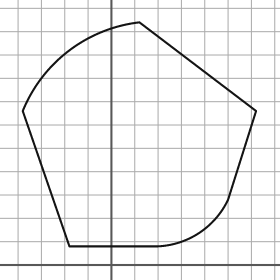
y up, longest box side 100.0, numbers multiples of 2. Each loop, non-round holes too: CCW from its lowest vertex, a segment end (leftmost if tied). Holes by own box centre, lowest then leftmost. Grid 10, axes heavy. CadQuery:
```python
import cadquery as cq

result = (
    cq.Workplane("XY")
    .moveTo(-18.0, 8.0)
    .lineTo(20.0, 8.0)
    .threePointArc((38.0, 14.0), (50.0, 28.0))
    .lineTo(62.0, 66.0)
    .lineTo(12.0, 104.0)
    .threePointArc((-18.0, 92.0), (-38.0, 66.0))
    .close()
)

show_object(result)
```